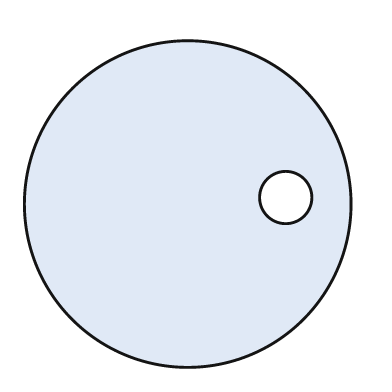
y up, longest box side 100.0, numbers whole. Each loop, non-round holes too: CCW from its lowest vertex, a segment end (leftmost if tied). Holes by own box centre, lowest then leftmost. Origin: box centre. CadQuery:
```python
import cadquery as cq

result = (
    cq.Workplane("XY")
    .moveTo(0.0, 0.0)
    .circle(50.0)
    .moveTo(30.0, 2.0)
    .circle(8.0)
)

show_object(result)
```